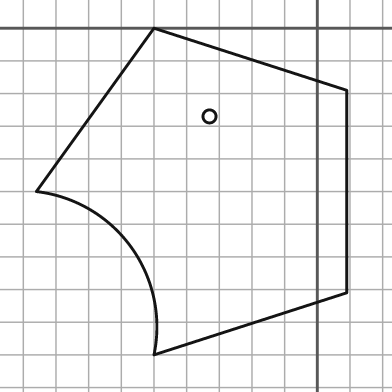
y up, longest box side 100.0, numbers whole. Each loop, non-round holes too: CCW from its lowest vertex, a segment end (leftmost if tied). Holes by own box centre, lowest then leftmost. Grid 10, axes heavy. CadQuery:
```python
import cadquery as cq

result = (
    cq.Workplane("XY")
    .moveTo(-50.0, -100.0)
    .lineTo(9.0, -81.0)
    .lineTo(9.0, -19.0)
    .lineTo(-50.0, 0.0)
    .lineTo(-86.0, -50.0)
    .threePointArc((-57.0, -67.0), (-50.0, -100.0))
    .close()
    .moveTo(-33.0, -27.0)
    .circle(2.0)
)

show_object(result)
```